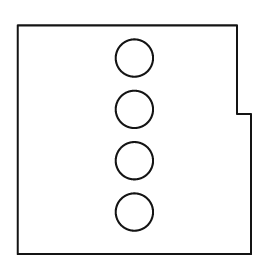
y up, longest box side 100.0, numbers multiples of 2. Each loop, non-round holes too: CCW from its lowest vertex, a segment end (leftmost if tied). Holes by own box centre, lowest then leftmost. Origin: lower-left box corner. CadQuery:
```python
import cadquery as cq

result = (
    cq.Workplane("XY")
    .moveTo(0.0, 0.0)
    .lineTo(100.0, 0.0)
    .lineTo(100.0, 60.0)
    .lineTo(94.0, 60.0)
    .lineTo(94.0, 98.0)
    .lineTo(0.0, 98.0)
    .close()
    .moveTo(50.0, 18.0)
    .circle(8.0)
    .moveTo(50.0, 40.0)
    .circle(8.0)
    .moveTo(50.0, 62.0)
    .circle(8.0)
    .moveTo(50.0, 84.0)
    .circle(8.0)
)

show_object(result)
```